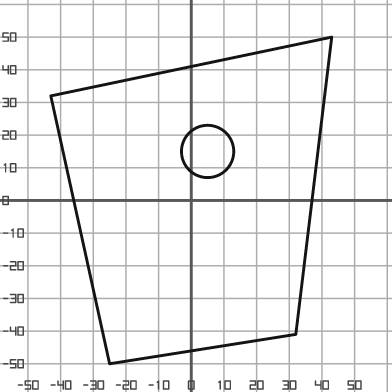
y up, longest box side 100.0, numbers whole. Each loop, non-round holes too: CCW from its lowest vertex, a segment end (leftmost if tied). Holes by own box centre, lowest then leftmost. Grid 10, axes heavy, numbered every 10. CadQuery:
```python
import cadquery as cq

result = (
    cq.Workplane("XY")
    .moveTo(-25.0, -50.0)
    .lineTo(32.0, -41.0)
    .lineTo(43.0, 50.0)
    .lineTo(-43.0, 32.0)
    .close()
    .moveTo(5.0, 15.0)
    .circle(8.0)
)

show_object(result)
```